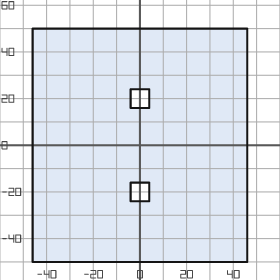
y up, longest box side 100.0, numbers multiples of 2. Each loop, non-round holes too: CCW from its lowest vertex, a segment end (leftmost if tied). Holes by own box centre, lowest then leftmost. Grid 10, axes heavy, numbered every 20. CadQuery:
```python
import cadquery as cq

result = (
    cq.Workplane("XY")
    .moveTo(-46.0, -50.0)
    .lineTo(46.0, -50.0)
    .lineTo(46.0, 50.0)
    .lineTo(-46.0, 50.0)
    .close()
    .moveTo(-4.0, -24.0)
    .lineTo(4.0, -24.0)
    .lineTo(4.0, -16.0)
    .lineTo(-4.0, -16.0)
    .close()
    .moveTo(-4.0, 16.0)
    .lineTo(4.0, 16.0)
    .lineTo(4.0, 24.0)
    .lineTo(-4.0, 24.0)
    .close()
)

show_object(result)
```